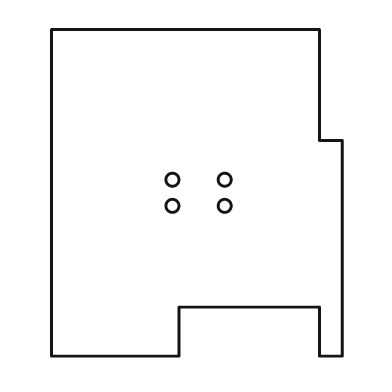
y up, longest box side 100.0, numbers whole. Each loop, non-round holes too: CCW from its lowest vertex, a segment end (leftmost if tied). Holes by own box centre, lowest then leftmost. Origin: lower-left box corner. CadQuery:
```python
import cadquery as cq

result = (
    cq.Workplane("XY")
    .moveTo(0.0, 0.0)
    .lineTo(39.0, 0.0)
    .lineTo(39.0, 15.0)
    .lineTo(82.0, 15.0)
    .lineTo(82.0, 0.0)
    .lineTo(89.0, 0.0)
    .lineTo(89.0, 66.0)
    .lineTo(82.0, 66.0)
    .lineTo(82.0, 100.0)
    .lineTo(0.0, 100.0)
    .close()
    .moveTo(37.0, 46.0)
    .circle(2.0)
    .moveTo(53.0, 46.0)
    .circle(2.0)
    .moveTo(37.0, 54.0)
    .circle(2.0)
    .moveTo(53.0, 54.0)
    .circle(2.0)
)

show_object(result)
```